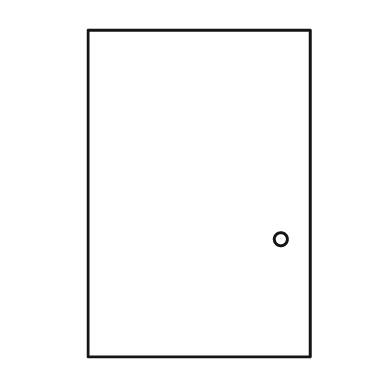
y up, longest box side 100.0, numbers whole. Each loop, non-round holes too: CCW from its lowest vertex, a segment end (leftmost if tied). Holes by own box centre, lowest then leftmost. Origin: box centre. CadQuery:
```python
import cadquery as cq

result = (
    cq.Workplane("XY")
    .moveTo(-34.0, -50.0)
    .lineTo(34.0, -50.0)
    .lineTo(34.0, 50.0)
    .lineTo(-34.0, 50.0)
    .close()
    .moveTo(25.0, -14.0)
    .circle(2.0)
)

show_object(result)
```